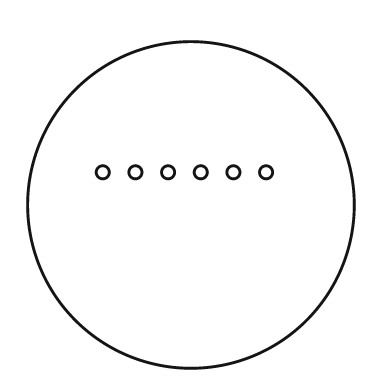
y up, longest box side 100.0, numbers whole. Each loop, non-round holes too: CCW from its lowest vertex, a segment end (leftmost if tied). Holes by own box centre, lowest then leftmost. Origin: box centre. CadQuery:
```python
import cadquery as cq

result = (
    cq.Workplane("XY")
    .moveTo(0.0, 0.0)
    .circle(50.0)
    .moveTo(-27.0, 10.0)
    .circle(2.0)
    .moveTo(-17.0, 10.0)
    .circle(2.0)
    .moveTo(-7.0, 10.0)
    .circle(2.0)
    .moveTo(3.0, 10.0)
    .circle(2.0)
    .moveTo(13.0, 10.0)
    .circle(2.0)
    .moveTo(23.0, 10.0)
    .circle(2.0)
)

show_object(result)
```